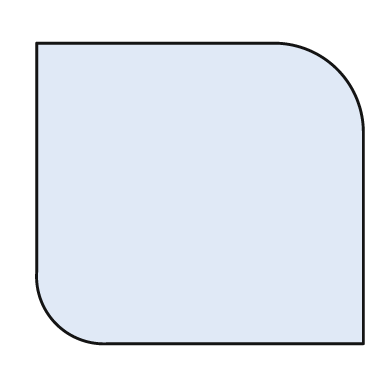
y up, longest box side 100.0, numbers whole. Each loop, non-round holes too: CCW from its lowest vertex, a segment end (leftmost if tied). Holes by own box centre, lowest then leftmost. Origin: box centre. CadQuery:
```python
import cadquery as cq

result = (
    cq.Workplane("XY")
    .moveTo(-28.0, -46.0)
    .lineTo(50.0, -46.0)
    .lineTo(50.0, 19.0)
    .threePointArc((42.0, 38.0), (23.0, 46.0))
    .lineTo(-50.0, 46.0)
    .lineTo(-50.0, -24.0)
    .threePointArc((-44.0, -40.0), (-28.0, -46.0))
    .close()
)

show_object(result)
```